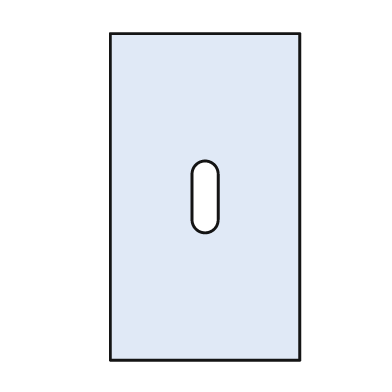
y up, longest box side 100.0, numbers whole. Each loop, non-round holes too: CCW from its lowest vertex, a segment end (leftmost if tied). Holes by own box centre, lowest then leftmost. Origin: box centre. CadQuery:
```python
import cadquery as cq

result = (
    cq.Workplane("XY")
    .moveTo(-29.0, -50.0)
    .lineTo(29.0, -50.0)
    .lineTo(29.0, 50.0)
    .lineTo(-29.0, 50.0)
    .close()
    .moveTo(-4.0, -7.0)
    .threePointArc((0.0, -11.0), (4.0, -7.0))
    .lineTo(4.0, 7.0)
    .threePointArc((0.0, 11.0), (-4.0, 7.0))
    .close()
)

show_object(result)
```